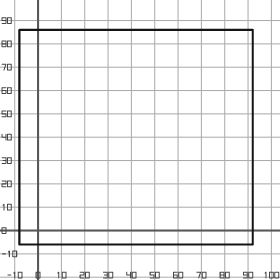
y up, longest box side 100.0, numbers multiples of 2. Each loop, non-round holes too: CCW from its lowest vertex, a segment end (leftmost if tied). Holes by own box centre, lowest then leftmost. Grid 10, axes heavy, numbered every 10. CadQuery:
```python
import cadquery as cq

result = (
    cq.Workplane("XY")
    .moveTo(-8.0, -6.0)
    .lineTo(92.0, -6.0)
    .lineTo(92.0, 86.0)
    .lineTo(-8.0, 86.0)
    .close()
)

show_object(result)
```